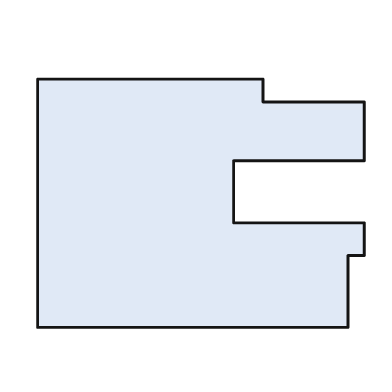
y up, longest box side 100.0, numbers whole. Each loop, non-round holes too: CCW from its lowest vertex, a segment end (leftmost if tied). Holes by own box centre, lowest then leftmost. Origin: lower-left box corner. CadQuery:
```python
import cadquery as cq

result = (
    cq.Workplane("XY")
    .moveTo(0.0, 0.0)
    .lineTo(95.0, 0.0)
    .lineTo(95.0, 22.0)
    .lineTo(100.0, 22.0)
    .lineTo(100.0, 32.0)
    .lineTo(60.0, 32.0)
    .lineTo(60.0, 51.0)
    .lineTo(100.0, 51.0)
    .lineTo(100.0, 69.0)
    .lineTo(69.0, 69.0)
    .lineTo(69.0, 76.0)
    .lineTo(0.0, 76.0)
    .close()
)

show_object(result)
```